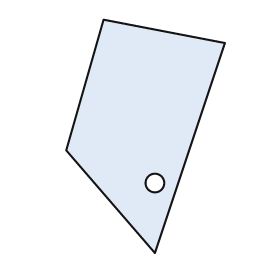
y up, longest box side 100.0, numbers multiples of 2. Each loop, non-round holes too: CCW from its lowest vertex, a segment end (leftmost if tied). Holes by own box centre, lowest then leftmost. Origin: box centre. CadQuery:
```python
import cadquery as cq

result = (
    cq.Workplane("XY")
    .moveTo(4.0, -50.0)
    .lineTo(34.0, 40.0)
    .lineTo(-18.0, 50.0)
    .lineTo(-34.0, -6.0)
    .close()
    .moveTo(4.0, -20.0)
    .circle(4.0)
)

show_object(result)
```